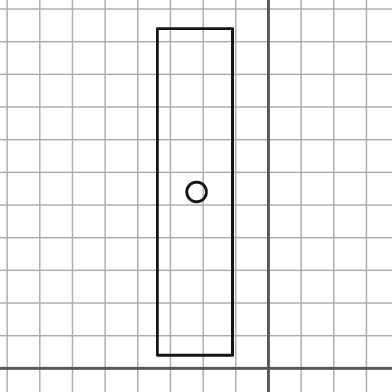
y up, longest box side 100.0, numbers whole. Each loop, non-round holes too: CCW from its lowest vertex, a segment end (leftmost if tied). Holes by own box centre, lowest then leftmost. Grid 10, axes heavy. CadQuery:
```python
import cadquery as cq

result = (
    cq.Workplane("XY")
    .moveTo(-34.0, 4.0)
    .lineTo(-11.0, 4.0)
    .lineTo(-11.0, 104.0)
    .lineTo(-34.0, 104.0)
    .close()
    .moveTo(-22.0, 54.0)
    .circle(3.0)
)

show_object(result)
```